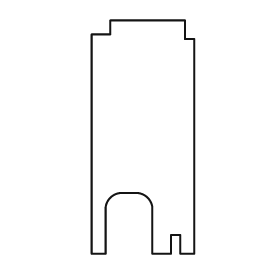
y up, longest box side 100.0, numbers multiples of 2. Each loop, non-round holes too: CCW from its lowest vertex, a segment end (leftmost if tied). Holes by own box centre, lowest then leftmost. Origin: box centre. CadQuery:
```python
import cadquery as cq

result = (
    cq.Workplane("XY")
    .moveTo(-22.0, -50.0)
    .lineTo(-16.0, -50.0)
    .lineTo(-16.0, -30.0)
    .threePointArc((-14.0, -26.0), (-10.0, -24.0))
    .lineTo(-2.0, -24.0)
    .threePointArc((2.0, -26.0), (4.0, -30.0))
    .lineTo(4.0, -50.0)
    .lineTo(12.0, -50.0)
    .lineTo(12.0, -42.0)
    .lineTo(16.0, -42.0)
    .lineTo(16.0, -50.0)
    .lineTo(22.0, -50.0)
    .lineTo(22.0, 42.0)
    .lineTo(18.0, 42.0)
    .lineTo(18.0, 50.0)
    .lineTo(-14.0, 50.0)
    .lineTo(-14.0, 44.0)
    .lineTo(-22.0, 44.0)
    .close()
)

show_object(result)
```